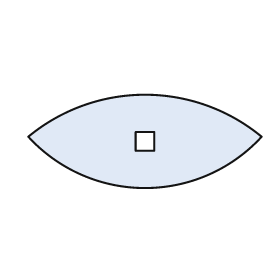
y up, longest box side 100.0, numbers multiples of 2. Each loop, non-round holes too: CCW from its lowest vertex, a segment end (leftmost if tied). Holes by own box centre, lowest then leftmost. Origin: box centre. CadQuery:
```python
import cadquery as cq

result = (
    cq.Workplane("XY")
    .moveTo(-50.0, 2.0)
    .threePointArc((0.0, -20.0), (50.0, 2.0))
    .threePointArc((0.0, 20.0), (-50.0, 2.0))
    .close()
    .moveTo(-4.0, -4.0)
    .lineTo(4.0, -4.0)
    .lineTo(4.0, 4.0)
    .lineTo(-4.0, 4.0)
    .close()
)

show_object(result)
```